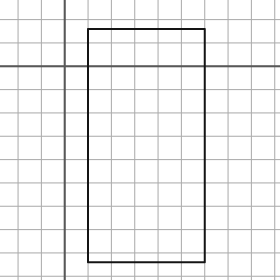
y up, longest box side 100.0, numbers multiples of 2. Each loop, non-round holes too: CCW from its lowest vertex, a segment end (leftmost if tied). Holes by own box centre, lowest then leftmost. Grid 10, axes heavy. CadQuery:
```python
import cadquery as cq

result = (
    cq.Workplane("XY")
    .moveTo(10.0, -84.0)
    .lineTo(60.0, -84.0)
    .lineTo(60.0, 16.0)
    .lineTo(10.0, 16.0)
    .close()
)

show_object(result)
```